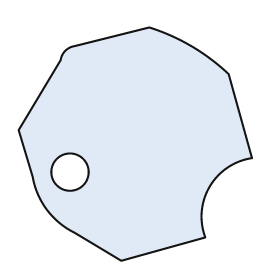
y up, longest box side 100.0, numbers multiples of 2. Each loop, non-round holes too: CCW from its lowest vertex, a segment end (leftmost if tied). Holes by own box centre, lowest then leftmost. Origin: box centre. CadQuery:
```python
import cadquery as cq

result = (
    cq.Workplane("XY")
    .moveTo(-6.0, -50.0)
    .lineTo(30.0, -40.0)
    .threePointArc((32.0, -18.0), (50.0, -6.0))
    .lineTo(40.0, 30.0)
    .threePointArc((24.0, 42.0), (6.0, 50.0))
    .lineTo(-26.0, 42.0)
    .threePointArc((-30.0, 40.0), (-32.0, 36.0))
    .lineTo(-50.0, 6.0)
    .lineTo(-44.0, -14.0)
    .threePointArc((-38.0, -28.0), (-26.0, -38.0))
    .close()
    .moveTo(-28.0, -12.0)
    .circle(8.0)
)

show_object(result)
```